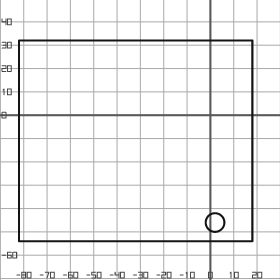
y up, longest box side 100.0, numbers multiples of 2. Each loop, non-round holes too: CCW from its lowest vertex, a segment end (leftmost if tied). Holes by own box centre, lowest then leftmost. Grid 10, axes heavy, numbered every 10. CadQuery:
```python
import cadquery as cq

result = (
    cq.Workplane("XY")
    .moveTo(-82.0, -54.0)
    .lineTo(18.0, -54.0)
    .lineTo(18.0, 32.0)
    .lineTo(-82.0, 32.0)
    .close()
    .moveTo(2.0, -46.0)
    .circle(4.0)
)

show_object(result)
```